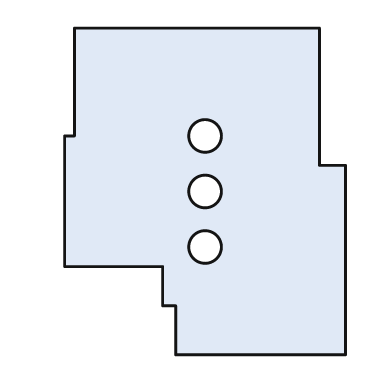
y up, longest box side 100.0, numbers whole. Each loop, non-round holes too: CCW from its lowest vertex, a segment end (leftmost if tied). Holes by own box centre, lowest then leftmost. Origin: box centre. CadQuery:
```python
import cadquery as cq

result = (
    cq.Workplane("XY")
    .moveTo(-9.0, -50.0)
    .lineTo(43.0, -50.0)
    .lineTo(43.0, 8.0)
    .lineTo(35.0, 8.0)
    .lineTo(35.0, 50.0)
    .lineTo(-40.0, 50.0)
    .lineTo(-40.0, 17.0)
    .lineTo(-43.0, 17.0)
    .lineTo(-43.0, -23.0)
    .lineTo(-13.0, -23.0)
    .lineTo(-13.0, -35.0)
    .lineTo(-9.0, -35.0)
    .close()
    .moveTo(0.0, -17.0)
    .circle(5.0)
    .moveTo(0.0, 0.0)
    .circle(5.0)
    .moveTo(0.0, 17.0)
    .circle(5.0)
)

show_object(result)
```